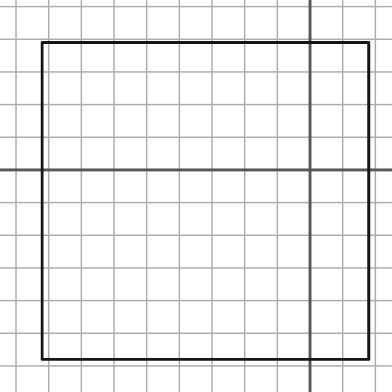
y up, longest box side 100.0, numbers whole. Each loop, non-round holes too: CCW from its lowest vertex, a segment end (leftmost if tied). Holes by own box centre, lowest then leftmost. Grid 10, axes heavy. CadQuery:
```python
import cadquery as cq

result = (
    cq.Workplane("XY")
    .moveTo(-82.0, -58.0)
    .lineTo(18.0, -58.0)
    .lineTo(18.0, 39.0)
    .lineTo(-82.0, 39.0)
    .close()
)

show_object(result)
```